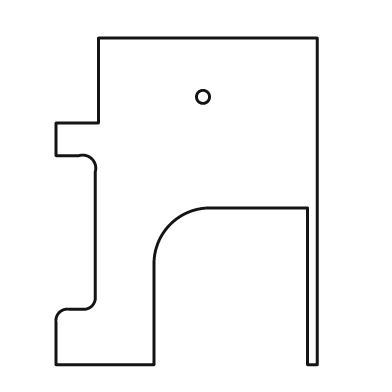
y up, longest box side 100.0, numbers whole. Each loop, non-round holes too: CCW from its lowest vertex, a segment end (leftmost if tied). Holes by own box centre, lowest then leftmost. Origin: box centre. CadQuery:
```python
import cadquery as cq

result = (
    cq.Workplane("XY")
    .moveTo(-40.0, -50.0)
    .lineTo(-10.0, -50.0)
    .lineTo(-10.0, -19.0)
    .threePointArc((-5.0, -7.0), (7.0, -2.0))
    .lineTo(37.0, -2.0)
    .lineTo(37.0, -50.0)
    .lineTo(40.0, -50.0)
    .lineTo(40.0, 50.0)
    .lineTo(-27.0, 50.0)
    .lineTo(-27.0, 24.0)
    .lineTo(-40.0, 24.0)
    .lineTo(-40.0, 14.0)
    .lineTo(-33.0, 14.0)
    .threePointArc((-29.0, 13.0), (-28.0, 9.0))
    .lineTo(-28.0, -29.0)
    .threePointArc((-29.0, -32.0), (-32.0, -33.0))
    .lineTo(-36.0, -33.0)
    .threePointArc((-39.0, -34.0), (-40.0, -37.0))
    .close()
    .moveTo(5.0, 32.0)
    .circle(2.0)
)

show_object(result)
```